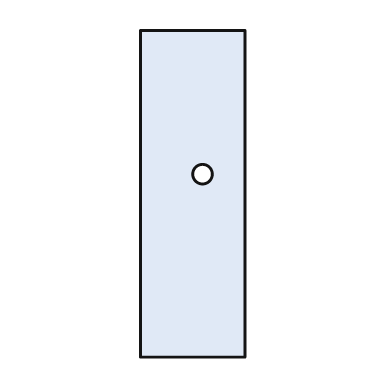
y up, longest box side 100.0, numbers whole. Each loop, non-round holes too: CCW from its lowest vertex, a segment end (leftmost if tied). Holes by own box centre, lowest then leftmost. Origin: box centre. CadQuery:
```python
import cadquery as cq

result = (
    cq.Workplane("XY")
    .moveTo(-16.0, -50.0)
    .lineTo(16.0, -50.0)
    .lineTo(16.0, 50.0)
    .lineTo(-16.0, 50.0)
    .close()
    .moveTo(3.0, 6.0)
    .circle(3.0)
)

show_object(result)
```